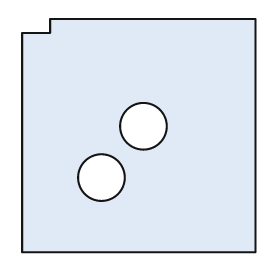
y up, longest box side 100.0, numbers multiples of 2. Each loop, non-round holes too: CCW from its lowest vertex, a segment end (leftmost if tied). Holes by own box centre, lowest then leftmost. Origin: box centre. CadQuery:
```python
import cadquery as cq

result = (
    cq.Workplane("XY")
    .moveTo(-50.0, -50.0)
    .lineTo(50.0, -50.0)
    .lineTo(50.0, 50.0)
    .lineTo(-38.0, 50.0)
    .lineTo(-38.0, 44.0)
    .lineTo(-50.0, 44.0)
    .close()
    .moveTo(-16.0, -18.0)
    .circle(10.0)
    .moveTo(2.0, 4.0)
    .circle(10.0)
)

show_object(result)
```